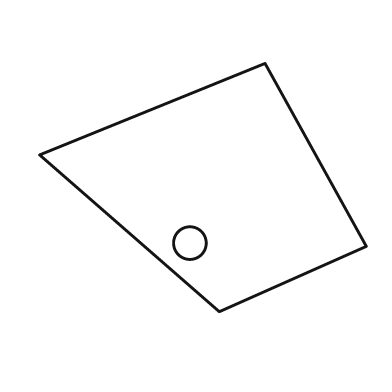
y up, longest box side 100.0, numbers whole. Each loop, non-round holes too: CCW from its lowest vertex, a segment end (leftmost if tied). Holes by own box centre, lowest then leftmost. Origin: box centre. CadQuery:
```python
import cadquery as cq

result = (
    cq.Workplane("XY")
    .moveTo(5.0, -38.0)
    .lineTo(50.0, -18.0)
    .lineTo(19.0, 38.0)
    .lineTo(-50.0, 10.0)
    .close()
    .moveTo(-4.0, -17.0)
    .circle(5.0)
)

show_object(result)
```